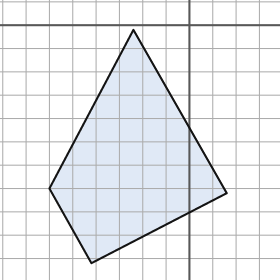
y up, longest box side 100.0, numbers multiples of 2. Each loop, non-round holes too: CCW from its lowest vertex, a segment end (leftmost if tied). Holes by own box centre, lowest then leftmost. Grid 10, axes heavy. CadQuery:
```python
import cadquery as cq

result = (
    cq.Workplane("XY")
    .moveTo(-42.0, -102.0)
    .lineTo(16.0, -72.0)
    .lineTo(-24.0, -2.0)
    .lineTo(-60.0, -70.0)
    .close()
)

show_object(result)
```